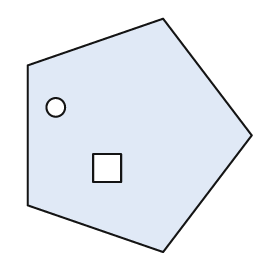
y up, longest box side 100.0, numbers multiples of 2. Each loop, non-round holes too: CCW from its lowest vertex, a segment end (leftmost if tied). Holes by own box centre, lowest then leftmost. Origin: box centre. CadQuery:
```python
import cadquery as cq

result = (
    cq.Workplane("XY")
    .moveTo(10.0, -50.0)
    .lineTo(48.0, 0.0)
    .lineTo(10.0, 50.0)
    .lineTo(-48.0, 30.0)
    .lineTo(-48.0, -30.0)
    .close()
    .moveTo(-20.0, -20.0)
    .lineTo(-8.0, -20.0)
    .lineTo(-8.0, -8.0)
    .lineTo(-20.0, -8.0)
    .close()
    .moveTo(-36.0, 12.0)
    .circle(4.0)
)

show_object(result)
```